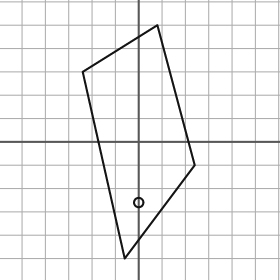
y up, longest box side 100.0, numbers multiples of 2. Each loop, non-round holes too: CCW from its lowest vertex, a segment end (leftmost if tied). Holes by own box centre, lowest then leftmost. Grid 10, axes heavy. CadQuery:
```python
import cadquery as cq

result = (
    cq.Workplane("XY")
    .moveTo(-6.0, -50.0)
    .lineTo(24.0, -10.0)
    .lineTo(8.0, 50.0)
    .lineTo(-24.0, 30.0)
    .close()
    .moveTo(0.0, -26.0)
    .circle(2.0)
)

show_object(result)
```